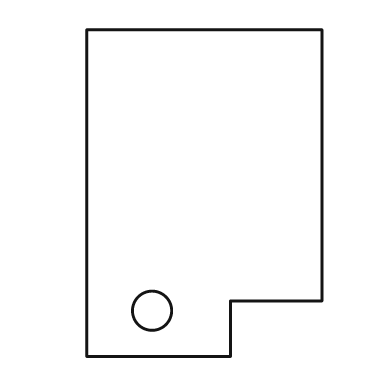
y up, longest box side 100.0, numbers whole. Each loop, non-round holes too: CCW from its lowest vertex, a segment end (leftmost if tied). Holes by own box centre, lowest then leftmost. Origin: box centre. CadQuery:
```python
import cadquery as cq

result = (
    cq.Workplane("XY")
    .moveTo(-36.0, -50.0)
    .lineTo(8.0, -50.0)
    .lineTo(8.0, -33.0)
    .lineTo(36.0, -33.0)
    .lineTo(36.0, 50.0)
    .lineTo(-36.0, 50.0)
    .close()
    .moveTo(-16.0, -36.0)
    .circle(6.0)
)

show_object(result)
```